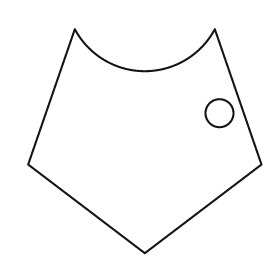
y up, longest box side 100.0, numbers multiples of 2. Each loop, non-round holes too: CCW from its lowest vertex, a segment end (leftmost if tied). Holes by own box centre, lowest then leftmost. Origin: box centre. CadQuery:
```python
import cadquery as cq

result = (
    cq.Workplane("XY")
    .moveTo(0.0, -48.0)
    .lineTo(50.0, -10.0)
    .lineTo(30.0, 48.0)
    .threePointArc((0.0, 30.0), (-30.0, 48.0))
    .lineTo(-50.0, -10.0)
    .close()
    .moveTo(32.0, 12.0)
    .circle(6.0)
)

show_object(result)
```